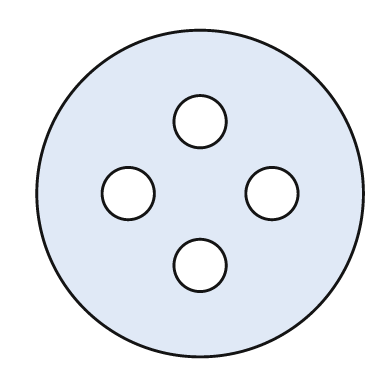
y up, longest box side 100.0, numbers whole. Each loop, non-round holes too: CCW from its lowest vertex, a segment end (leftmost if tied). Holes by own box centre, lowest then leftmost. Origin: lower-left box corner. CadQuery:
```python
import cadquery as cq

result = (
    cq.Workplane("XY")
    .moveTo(50.0, 50.0)
    .circle(50.0)
    .moveTo(50.0, 28.0)
    .circle(8.0)
    .moveTo(28.0, 50.0)
    .circle(8.0)
    .moveTo(72.0, 50.0)
    .circle(8.0)
    .moveTo(50.0, 72.0)
    .circle(8.0)
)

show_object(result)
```